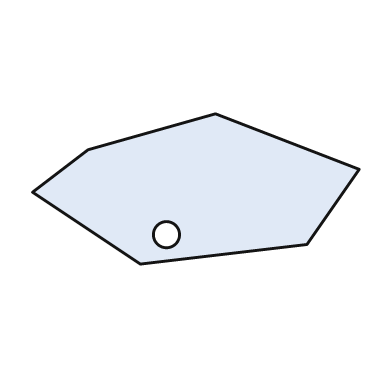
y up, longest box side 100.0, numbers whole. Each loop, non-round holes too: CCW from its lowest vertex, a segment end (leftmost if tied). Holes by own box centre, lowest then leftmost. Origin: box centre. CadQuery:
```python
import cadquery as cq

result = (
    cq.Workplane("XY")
    .moveTo(-17.0, -23.0)
    .lineTo(34.0, -17.0)
    .lineTo(50.0, 6.0)
    .lineTo(6.0, 23.0)
    .lineTo(-33.0, 12.0)
    .lineTo(-50.0, -1.0)
    .close()
    .moveTo(-9.0, -14.0)
    .circle(4.0)
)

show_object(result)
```